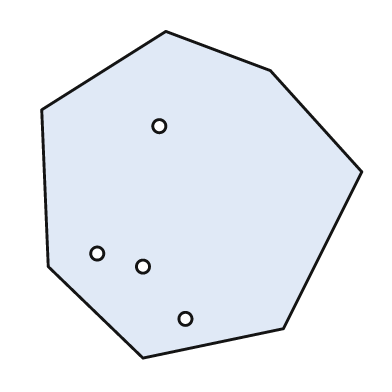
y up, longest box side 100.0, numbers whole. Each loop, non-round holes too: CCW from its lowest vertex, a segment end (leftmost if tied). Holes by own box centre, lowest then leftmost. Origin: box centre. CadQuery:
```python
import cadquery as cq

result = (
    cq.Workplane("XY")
    .moveTo(-18.0, -50.0)
    .lineTo(25.0, -41.0)
    .lineTo(49.0, 7.0)
    .lineTo(21.0, 38.0)
    .lineTo(-11.0, 50.0)
    .lineTo(-49.0, 26.0)
    .lineTo(-47.0, -22.0)
    .close()
    .moveTo(-5.0, -38.0)
    .circle(2.0)
    .moveTo(-18.0, -22.0)
    .circle(2.0)
    .moveTo(-32.0, -18.0)
    .circle(2.0)
    .moveTo(-13.0, 21.0)
    .circle(2.0)
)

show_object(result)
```